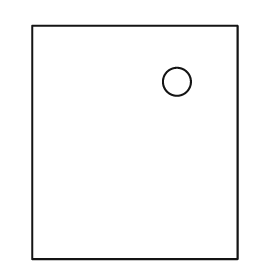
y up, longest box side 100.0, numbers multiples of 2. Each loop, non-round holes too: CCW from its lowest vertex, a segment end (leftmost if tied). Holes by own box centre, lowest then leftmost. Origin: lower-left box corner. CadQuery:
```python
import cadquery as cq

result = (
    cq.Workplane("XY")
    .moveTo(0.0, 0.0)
    .lineTo(88.0, 0.0)
    .lineTo(88.0, 100.0)
    .lineTo(0.0, 100.0)
    .close()
    .moveTo(62.0, 76.0)
    .circle(6.0)
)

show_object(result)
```